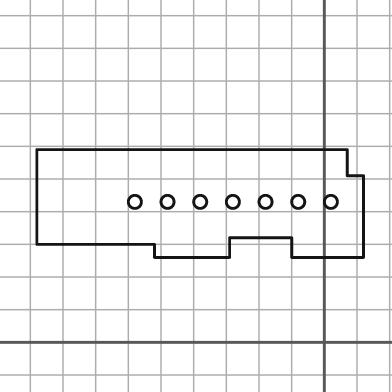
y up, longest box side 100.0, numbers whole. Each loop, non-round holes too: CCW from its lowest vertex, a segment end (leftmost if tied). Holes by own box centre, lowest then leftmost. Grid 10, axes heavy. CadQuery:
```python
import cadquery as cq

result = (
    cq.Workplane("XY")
    .moveTo(-52.0, 26.0)
    .lineTo(-29.0, 26.0)
    .lineTo(-29.0, 32.0)
    .lineTo(-10.0, 32.0)
    .lineTo(-10.0, 26.0)
    .lineTo(12.0, 26.0)
    .lineTo(12.0, 51.0)
    .lineTo(7.0, 51.0)
    .lineTo(7.0, 59.0)
    .lineTo(-88.0, 59.0)
    .lineTo(-88.0, 30.0)
    .lineTo(-52.0, 30.0)
    .close()
    .moveTo(-58.0, 43.0)
    .circle(2.0)
    .moveTo(-48.0, 43.0)
    .circle(2.0)
    .moveTo(-38.0, 43.0)
    .circle(2.0)
    .moveTo(-28.0, 43.0)
    .circle(2.0)
    .moveTo(-18.0, 43.0)
    .circle(2.0)
    .moveTo(-8.0, 43.0)
    .circle(2.0)
    .moveTo(2.0, 43.0)
    .circle(2.0)
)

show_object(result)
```